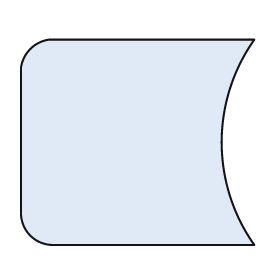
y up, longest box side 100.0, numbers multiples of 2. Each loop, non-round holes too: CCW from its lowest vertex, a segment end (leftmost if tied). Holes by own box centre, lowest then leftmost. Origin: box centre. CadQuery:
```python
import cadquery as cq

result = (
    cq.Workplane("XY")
    .moveTo(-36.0, -44.0)
    .lineTo(50.0, -44.0)
    .threePointArc((36.0, 0.0), (50.0, 44.0))
    .lineTo(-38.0, 44.0)
    .threePointArc((-46.0, 40.0), (-50.0, 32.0))
    .lineTo(-50.0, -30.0)
    .threePointArc((-46.0, -40.0), (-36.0, -44.0))
    .close()
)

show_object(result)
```